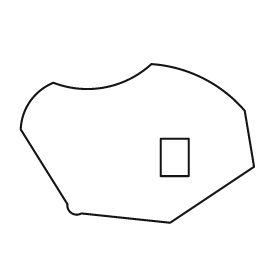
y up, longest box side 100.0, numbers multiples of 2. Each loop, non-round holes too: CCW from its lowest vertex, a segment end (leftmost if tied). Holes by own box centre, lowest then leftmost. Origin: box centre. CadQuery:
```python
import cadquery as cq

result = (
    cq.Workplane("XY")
    .moveTo(14.0, -34.0)
    .lineTo(50.0, -10.0)
    .lineTo(46.0, 14.0)
    .threePointArc((28.0, 28.0), (6.0, 34.0))
    .threePointArc((-14.0, 24.0), (-36.0, 26.0))
    .threePointArc((-46.0, 18.0), (-50.0, 6.0))
    .lineTo(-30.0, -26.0)
    .threePointArc((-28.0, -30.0), (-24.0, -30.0))
    .close()
    .moveTo(10.0, -14.0)
    .lineTo(22.0, -14.0)
    .lineTo(22.0, 2.0)
    .lineTo(10.0, 2.0)
    .close()
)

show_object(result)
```